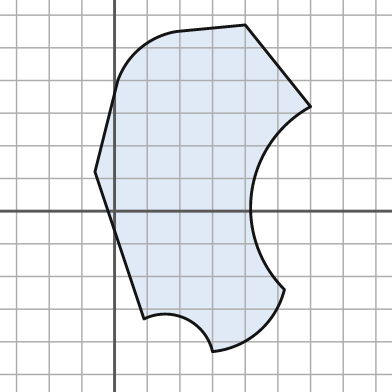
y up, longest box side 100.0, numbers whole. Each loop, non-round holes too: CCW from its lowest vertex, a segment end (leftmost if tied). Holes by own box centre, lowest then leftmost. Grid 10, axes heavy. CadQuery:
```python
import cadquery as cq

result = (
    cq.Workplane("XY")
    .moveTo(30.0, -43.0)
    .threePointArc((44.0, -37.0), (52.0, -24.0))
    .threePointArc((42.0, 6.0), (60.0, 32.0))
    .lineTo(40.0, 57.0)
    .lineTo(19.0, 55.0)
    .threePointArc((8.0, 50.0), (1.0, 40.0))
    .lineTo(-6.0, 12.0)
    .lineTo(9.0, -33.0)
    .threePointArc((22.0, -33.0), (30.0, -43.0))
    .close()
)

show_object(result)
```